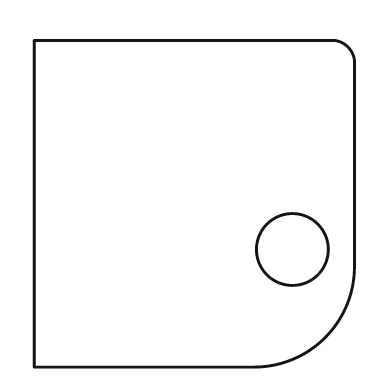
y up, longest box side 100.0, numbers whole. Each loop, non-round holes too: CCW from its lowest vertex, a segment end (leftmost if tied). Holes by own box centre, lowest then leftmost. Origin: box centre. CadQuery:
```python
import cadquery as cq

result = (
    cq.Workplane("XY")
    .moveTo(-49.0, -50.0)
    .lineTo(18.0, -50.0)
    .threePointArc((40.0, -41.0), (49.0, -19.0))
    .lineTo(49.0, 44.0)
    .threePointArc((47.0, 48.0), (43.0, 50.0))
    .lineTo(-49.0, 50.0)
    .close()
    .moveTo(30.0, -14.0)
    .circle(11.0)
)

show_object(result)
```